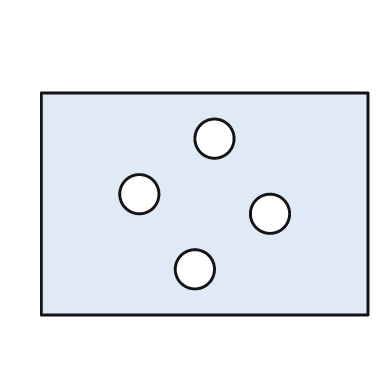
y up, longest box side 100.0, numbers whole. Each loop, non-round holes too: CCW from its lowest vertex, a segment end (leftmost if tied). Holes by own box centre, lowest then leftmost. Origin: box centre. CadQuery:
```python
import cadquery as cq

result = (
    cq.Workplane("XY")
    .moveTo(-50.0, -34.0)
    .lineTo(50.0, -34.0)
    .lineTo(50.0, 34.0)
    .lineTo(-50.0, 34.0)
    .close()
    .moveTo(-3.0, -20.0)
    .circle(6.0)
    .moveTo(20.0, -3.0)
    .circle(6.0)
    .moveTo(-20.0, 3.0)
    .circle(6.0)
    .moveTo(3.0, 20.0)
    .circle(6.0)
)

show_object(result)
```